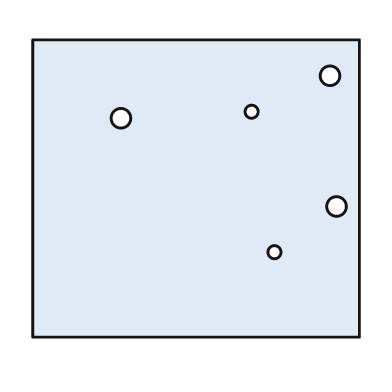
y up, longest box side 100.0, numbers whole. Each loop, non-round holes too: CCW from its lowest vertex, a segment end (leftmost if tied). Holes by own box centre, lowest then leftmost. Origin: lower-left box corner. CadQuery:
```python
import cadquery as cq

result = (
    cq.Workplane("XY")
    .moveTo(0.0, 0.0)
    .lineTo(100.0, 0.0)
    .lineTo(100.0, 91.0)
    .lineTo(0.0, 91.0)
    .close()
    .moveTo(74.0, 26.0)
    .circle(2.0)
    .moveTo(93.0, 40.0)
    .circle(3.0)
    .moveTo(27.0, 67.0)
    .circle(3.0)
    .moveTo(67.0, 69.0)
    .circle(2.0)
    .moveTo(91.0, 80.0)
    .circle(3.0)
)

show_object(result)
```